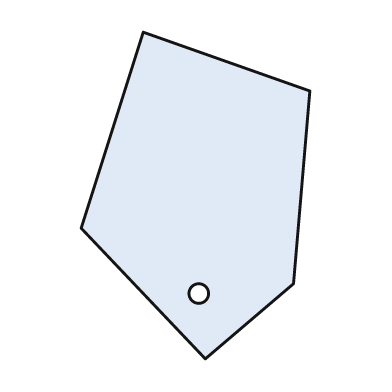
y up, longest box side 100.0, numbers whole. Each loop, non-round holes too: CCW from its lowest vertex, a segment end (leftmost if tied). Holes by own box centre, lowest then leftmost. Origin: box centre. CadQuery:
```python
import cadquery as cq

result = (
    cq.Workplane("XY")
    .moveTo(3.0, -50.0)
    .lineTo(30.0, -27.0)
    .lineTo(35.0, 32.0)
    .lineTo(-16.0, 50.0)
    .lineTo(-35.0, -10.0)
    .close()
    .moveTo(1.0, -30.0)
    .circle(3.0)
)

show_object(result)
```